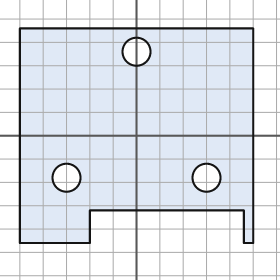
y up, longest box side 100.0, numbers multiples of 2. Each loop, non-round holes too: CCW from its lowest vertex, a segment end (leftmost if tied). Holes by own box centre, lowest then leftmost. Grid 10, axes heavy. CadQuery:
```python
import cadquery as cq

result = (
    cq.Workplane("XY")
    .moveTo(-50.0, -46.0)
    .lineTo(-20.0, -46.0)
    .lineTo(-20.0, -32.0)
    .lineTo(46.0, -32.0)
    .lineTo(46.0, -46.0)
    .lineTo(50.0, -46.0)
    .lineTo(50.0, 46.0)
    .lineTo(-50.0, 46.0)
    .close()
    .moveTo(-30.0, -18.0)
    .circle(6.0)
    .moveTo(30.0, -18.0)
    .circle(6.0)
    .moveTo(0.0, 36.0)
    .circle(6.0)
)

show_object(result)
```